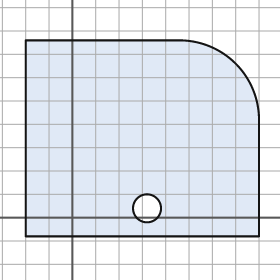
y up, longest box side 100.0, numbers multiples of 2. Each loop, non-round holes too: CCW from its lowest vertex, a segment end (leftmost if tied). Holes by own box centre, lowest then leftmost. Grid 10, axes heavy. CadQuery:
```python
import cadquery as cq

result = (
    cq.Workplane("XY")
    .moveTo(-20.0, -8.0)
    .lineTo(80.0, -8.0)
    .lineTo(80.0, 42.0)
    .threePointArc((70.0, 66.0), (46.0, 76.0))
    .lineTo(-20.0, 76.0)
    .close()
    .moveTo(32.0, 4.0)
    .circle(6.0)
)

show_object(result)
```